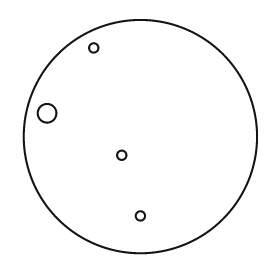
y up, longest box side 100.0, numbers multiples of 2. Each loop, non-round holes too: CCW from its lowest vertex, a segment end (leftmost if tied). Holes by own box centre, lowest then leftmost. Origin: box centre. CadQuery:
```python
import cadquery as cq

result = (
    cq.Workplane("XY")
    .moveTo(0.0, 0.0)
    .circle(50.0)
    .moveTo(0.0, -34.0)
    .circle(2.0)
    .moveTo(-8.0, -8.0)
    .circle(2.0)
    .moveTo(-40.0, 10.0)
    .circle(4.0)
    .moveTo(-20.0, 38.0)
    .circle(2.0)
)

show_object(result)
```